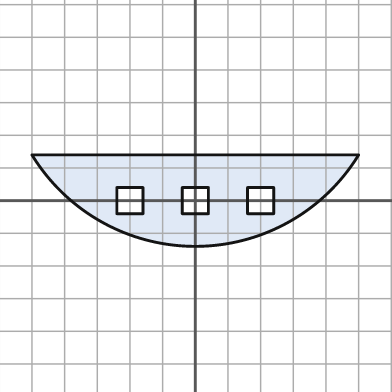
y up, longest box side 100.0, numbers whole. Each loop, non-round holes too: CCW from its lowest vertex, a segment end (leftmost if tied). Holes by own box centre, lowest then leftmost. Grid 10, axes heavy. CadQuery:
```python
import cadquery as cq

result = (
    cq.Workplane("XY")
    .moveTo(-50.0, 14.0)
    .threePointArc((0.0, -14.0), (50.0, 14.0))
    .close()
    .moveTo(-24.0, -4.0)
    .lineTo(-16.0, -4.0)
    .lineTo(-16.0, 4.0)
    .lineTo(-24.0, 4.0)
    .close()
    .moveTo(-4.0, -4.0)
    .lineTo(4.0, -4.0)
    .lineTo(4.0, 4.0)
    .lineTo(-4.0, 4.0)
    .close()
    .moveTo(16.0, -4.0)
    .lineTo(24.0, -4.0)
    .lineTo(24.0, 4.0)
    .lineTo(16.0, 4.0)
    .close()
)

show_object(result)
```